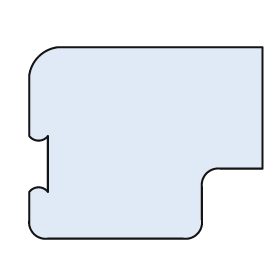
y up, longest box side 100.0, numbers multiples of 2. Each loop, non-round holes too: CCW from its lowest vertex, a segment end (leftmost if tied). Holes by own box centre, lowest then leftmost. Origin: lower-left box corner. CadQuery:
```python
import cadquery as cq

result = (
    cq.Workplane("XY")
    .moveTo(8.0, 0.0)
    .lineTo(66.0, 0.0)
    .threePointArc((72.0, 2.0), (74.0, 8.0))
    .lineTo(74.0, 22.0)
    .threePointArc((76.0, 28.0), (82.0, 30.0))
    .lineTo(100.0, 30.0)
    .lineTo(100.0, 82.0)
    .lineTo(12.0, 82.0)
    .threePointArc((4.0, 78.0), (0.0, 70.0))
    .lineTo(0.0, 44.0)
    .threePointArc((4.0, 42.0), (8.0, 44.0))
    .lineTo(8.0, 20.0)
    .threePointArc((4.0, 22.0), (0.0, 20.0))
    .lineTo(0.0, 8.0)
    .threePointArc((2.0, 2.0), (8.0, 0.0))
    .close()
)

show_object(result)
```